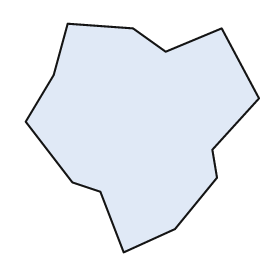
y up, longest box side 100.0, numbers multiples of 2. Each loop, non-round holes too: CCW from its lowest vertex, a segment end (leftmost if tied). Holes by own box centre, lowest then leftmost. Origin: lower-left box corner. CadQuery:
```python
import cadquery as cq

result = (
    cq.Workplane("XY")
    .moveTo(42.0, 0.0)
    .lineTo(64.0, 10.0)
    .lineTo(82.0, 32.0)
    .lineTo(80.0, 44.0)
    .lineTo(100.0, 66.0)
    .lineTo(84.0, 96.0)
    .lineTo(60.0, 86.0)
    .lineTo(46.0, 96.0)
    .lineTo(18.0, 98.0)
    .lineTo(12.0, 76.0)
    .lineTo(0.0, 56.0)
    .lineTo(20.0, 30.0)
    .lineTo(32.0, 26.0)
    .close()
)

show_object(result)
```